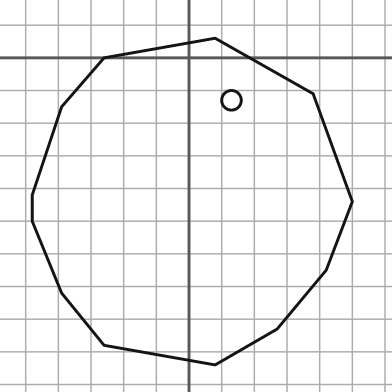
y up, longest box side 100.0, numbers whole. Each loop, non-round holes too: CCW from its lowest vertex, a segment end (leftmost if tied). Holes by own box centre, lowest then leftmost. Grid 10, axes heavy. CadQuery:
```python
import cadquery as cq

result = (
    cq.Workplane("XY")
    .moveTo(8.0, -94.0)
    .lineTo(27.0, -83.0)
    .lineTo(42.0, -65.0)
    .lineTo(50.0, -44.0)
    .lineTo(38.0, -11.0)
    .lineTo(8.0, 6.0)
    .lineTo(-26.0, 0.0)
    .lineTo(-39.0, -15.0)
    .lineTo(-48.0, -42.0)
    .lineTo(-48.0, -50.0)
    .lineTo(-39.0, -72.0)
    .lineTo(-26.0, -88.0)
    .close()
    .moveTo(13.0, -13.0)
    .circle(3.0)
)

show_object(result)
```